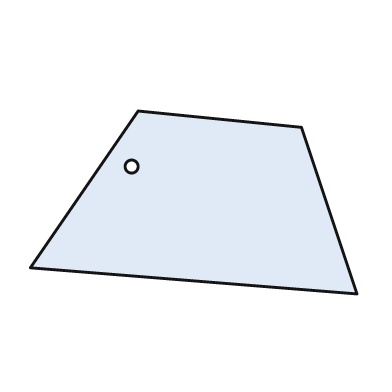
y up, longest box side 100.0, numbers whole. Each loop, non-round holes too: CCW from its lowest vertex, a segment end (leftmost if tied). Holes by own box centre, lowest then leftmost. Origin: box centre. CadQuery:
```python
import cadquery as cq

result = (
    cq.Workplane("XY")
    .moveTo(50.0, -28.0)
    .lineTo(33.0, 23.0)
    .lineTo(-17.0, 28.0)
    .lineTo(-50.0, -20.0)
    .close()
    .moveTo(-19.0, 11.0)
    .circle(2.0)
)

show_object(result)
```